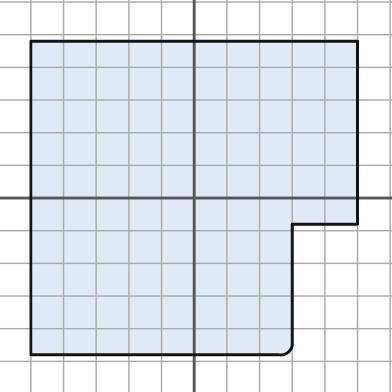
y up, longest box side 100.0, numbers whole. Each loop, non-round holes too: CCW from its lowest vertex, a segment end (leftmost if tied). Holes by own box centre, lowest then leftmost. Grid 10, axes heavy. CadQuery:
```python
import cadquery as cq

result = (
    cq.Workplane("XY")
    .moveTo(-50.0, -48.0)
    .lineTo(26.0, -48.0)
    .threePointArc((29.0, -47.0), (30.0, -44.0))
    .lineTo(30.0, -8.0)
    .lineTo(50.0, -8.0)
    .lineTo(50.0, 48.0)
    .lineTo(-50.0, 48.0)
    .close()
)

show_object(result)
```